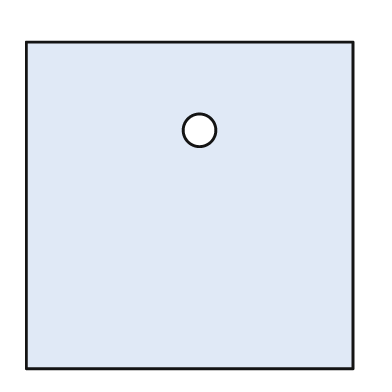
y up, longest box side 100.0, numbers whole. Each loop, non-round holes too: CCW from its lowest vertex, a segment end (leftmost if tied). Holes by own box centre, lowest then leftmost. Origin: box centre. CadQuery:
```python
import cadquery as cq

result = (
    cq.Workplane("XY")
    .moveTo(-50.0, -50.0)
    .lineTo(50.0, -50.0)
    .lineTo(50.0, 50.0)
    .lineTo(-50.0, 50.0)
    .close()
    .moveTo(3.0, 23.0)
    .circle(5.0)
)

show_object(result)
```